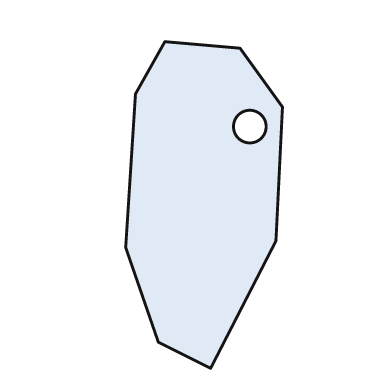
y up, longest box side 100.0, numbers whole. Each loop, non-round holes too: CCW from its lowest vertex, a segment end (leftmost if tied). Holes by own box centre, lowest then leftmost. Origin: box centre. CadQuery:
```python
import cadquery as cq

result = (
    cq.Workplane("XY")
    .moveTo(2.0, -50.0)
    .lineTo(22.0, -11.0)
    .lineTo(24.0, 30.0)
    .lineTo(11.0, 48.0)
    .lineTo(-12.0, 50.0)
    .lineTo(-21.0, 34.0)
    .lineTo(-24.0, -13.0)
    .lineTo(-14.0, -42.0)
    .close()
    .moveTo(14.0, 24.0)
    .circle(5.0)
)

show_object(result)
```